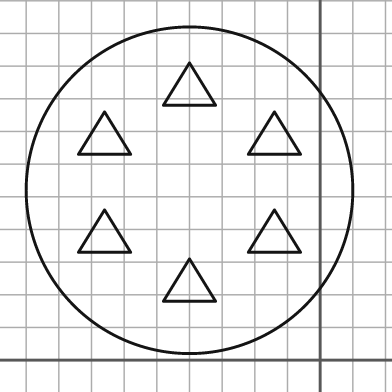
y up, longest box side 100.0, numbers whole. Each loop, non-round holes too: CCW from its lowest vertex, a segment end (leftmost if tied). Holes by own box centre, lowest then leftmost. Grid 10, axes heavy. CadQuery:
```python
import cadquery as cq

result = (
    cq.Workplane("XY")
    .moveTo(-40.0, 52.0)
    .circle(50.0)
    .moveTo(-48.0, 18.0)
    .lineTo(-32.0, 18.0)
    .lineTo(-40.0, 31.0)
    .close()
    .moveTo(-74.0, 33.0)
    .lineTo(-58.0, 33.0)
    .lineTo(-66.0, 46.0)
    .close()
    .moveTo(-22.0, 33.0)
    .lineTo(-6.0, 33.0)
    .lineTo(-14.0, 46.0)
    .close()
    .moveTo(-74.0, 63.0)
    .lineTo(-58.0, 63.0)
    .lineTo(-66.0, 76.0)
    .close()
    .moveTo(-22.0, 63.0)
    .lineTo(-6.0, 63.0)
    .lineTo(-14.0, 76.0)
    .close()
    .moveTo(-48.0, 78.0)
    .lineTo(-32.0, 78.0)
    .lineTo(-40.0, 91.0)
    .close()
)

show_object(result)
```